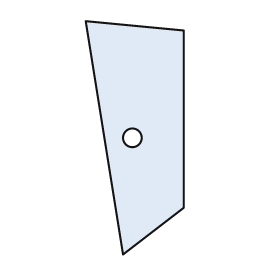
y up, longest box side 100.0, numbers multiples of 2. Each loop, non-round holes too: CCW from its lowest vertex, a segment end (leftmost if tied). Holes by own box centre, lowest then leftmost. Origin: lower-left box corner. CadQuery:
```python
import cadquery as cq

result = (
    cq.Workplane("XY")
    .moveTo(16.0, 0.0)
    .lineTo(42.0, 20.0)
    .lineTo(42.0, 96.0)
    .lineTo(0.0, 100.0)
    .close()
    .moveTo(20.0, 50.0)
    .circle(4.0)
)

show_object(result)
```